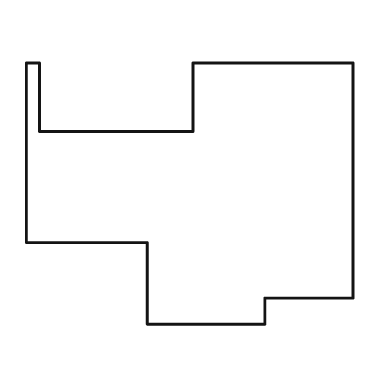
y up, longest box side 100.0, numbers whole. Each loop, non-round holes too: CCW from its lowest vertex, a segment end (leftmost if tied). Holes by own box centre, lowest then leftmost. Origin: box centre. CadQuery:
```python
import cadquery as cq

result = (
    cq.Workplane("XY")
    .moveTo(-13.0, -40.0)
    .lineTo(23.0, -40.0)
    .lineTo(23.0, -32.0)
    .lineTo(50.0, -32.0)
    .lineTo(50.0, 40.0)
    .lineTo(1.0, 40.0)
    .lineTo(1.0, 19.0)
    .lineTo(-46.0, 19.0)
    .lineTo(-46.0, 40.0)
    .lineTo(-50.0, 40.0)
    .lineTo(-50.0, -15.0)
    .lineTo(-13.0, -15.0)
    .close()
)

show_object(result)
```